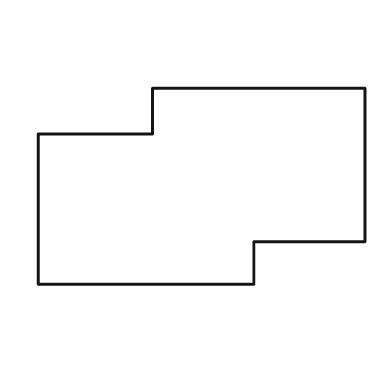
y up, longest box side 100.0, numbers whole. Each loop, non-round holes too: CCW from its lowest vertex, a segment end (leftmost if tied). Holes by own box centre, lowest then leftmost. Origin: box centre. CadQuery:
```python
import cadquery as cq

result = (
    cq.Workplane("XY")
    .moveTo(-50.0, -30.0)
    .lineTo(16.0, -30.0)
    .lineTo(16.0, -17.0)
    .lineTo(50.0, -17.0)
    .lineTo(50.0, 30.0)
    .lineTo(-15.0, 30.0)
    .lineTo(-15.0, 16.0)
    .lineTo(-50.0, 16.0)
    .close()
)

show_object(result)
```